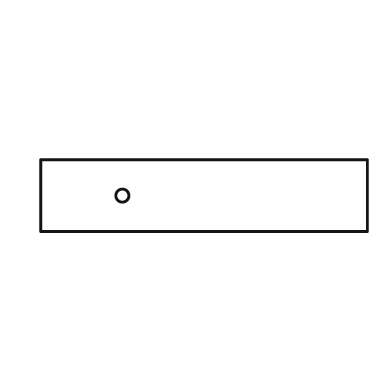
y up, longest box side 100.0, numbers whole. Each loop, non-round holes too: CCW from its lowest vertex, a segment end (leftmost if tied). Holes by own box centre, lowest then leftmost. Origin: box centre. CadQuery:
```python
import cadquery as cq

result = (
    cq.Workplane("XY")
    .moveTo(-50.0, -11.0)
    .lineTo(50.0, -11.0)
    .lineTo(50.0, 11.0)
    .lineTo(-50.0, 11.0)
    .close()
    .moveTo(-25.0, 0.0)
    .circle(2.0)
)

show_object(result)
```